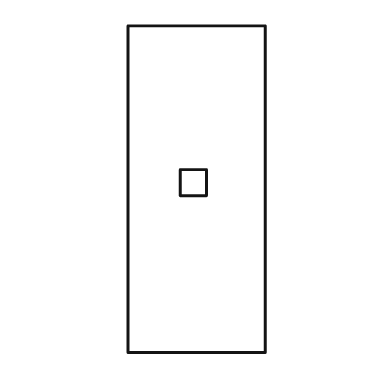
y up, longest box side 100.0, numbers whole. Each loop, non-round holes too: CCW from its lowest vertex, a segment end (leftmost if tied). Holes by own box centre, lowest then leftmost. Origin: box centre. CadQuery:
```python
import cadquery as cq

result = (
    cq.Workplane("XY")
    .moveTo(-21.0, -50.0)
    .lineTo(21.0, -50.0)
    .lineTo(21.0, 50.0)
    .lineTo(-21.0, 50.0)
    .close()
    .moveTo(-5.0, -2.0)
    .lineTo(3.0, -2.0)
    .lineTo(3.0, 6.0)
    .lineTo(-5.0, 6.0)
    .close()
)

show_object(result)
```